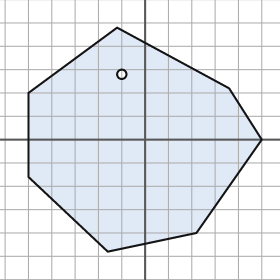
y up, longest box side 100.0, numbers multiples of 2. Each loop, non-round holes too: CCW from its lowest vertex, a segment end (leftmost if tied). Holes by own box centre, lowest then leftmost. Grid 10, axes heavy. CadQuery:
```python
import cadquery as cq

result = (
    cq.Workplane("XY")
    .moveTo(-16.0, -48.0)
    .lineTo(22.0, -40.0)
    .lineTo(50.0, 0.0)
    .lineTo(36.0, 22.0)
    .lineTo(-12.0, 48.0)
    .lineTo(-50.0, 20.0)
    .lineTo(-50.0, -16.0)
    .close()
    .moveTo(-10.0, 28.0)
    .circle(2.0)
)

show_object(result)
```